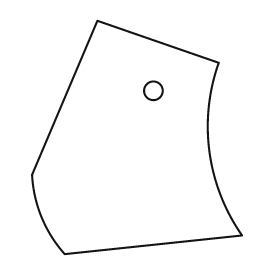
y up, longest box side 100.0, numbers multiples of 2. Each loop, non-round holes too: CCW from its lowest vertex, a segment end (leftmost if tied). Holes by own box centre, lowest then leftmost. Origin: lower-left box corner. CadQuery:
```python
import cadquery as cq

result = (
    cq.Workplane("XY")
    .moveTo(14.0, 0.0)
    .lineTo(90.0, 8.0)
    .threePointArc((76.0, 44.0), (80.0, 82.0))
    .lineTo(28.0, 100.0)
    .lineTo(0.0, 34.0)
    .threePointArc((4.0, 16.0), (14.0, 0.0))
    .close()
    .moveTo(52.0, 70.0)
    .circle(4.0)
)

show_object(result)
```